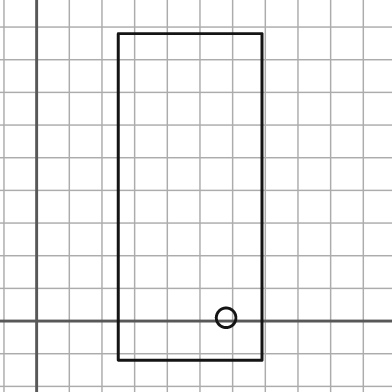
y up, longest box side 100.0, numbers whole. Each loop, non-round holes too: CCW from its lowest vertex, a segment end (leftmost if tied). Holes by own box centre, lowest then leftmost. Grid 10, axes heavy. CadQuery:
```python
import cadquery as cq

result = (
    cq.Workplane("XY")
    .moveTo(25.0, -12.0)
    .lineTo(69.0, -12.0)
    .lineTo(69.0, 88.0)
    .lineTo(25.0, 88.0)
    .close()
    .moveTo(58.0, 1.0)
    .circle(3.0)
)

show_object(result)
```